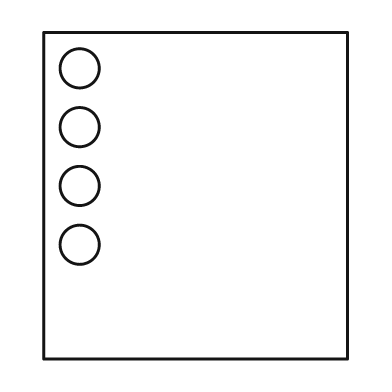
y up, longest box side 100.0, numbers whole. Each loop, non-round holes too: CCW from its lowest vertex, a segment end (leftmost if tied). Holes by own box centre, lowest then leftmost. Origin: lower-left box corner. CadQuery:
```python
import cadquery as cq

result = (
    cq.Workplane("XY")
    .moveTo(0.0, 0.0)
    .lineTo(93.0, 0.0)
    .lineTo(93.0, 100.0)
    .lineTo(0.0, 100.0)
    .close()
    .moveTo(11.0, 35.0)
    .circle(6.0)
    .moveTo(11.0, 53.0)
    .circle(6.0)
    .moveTo(11.0, 71.0)
    .circle(6.0)
    .moveTo(11.0, 89.0)
    .circle(6.0)
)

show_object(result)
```